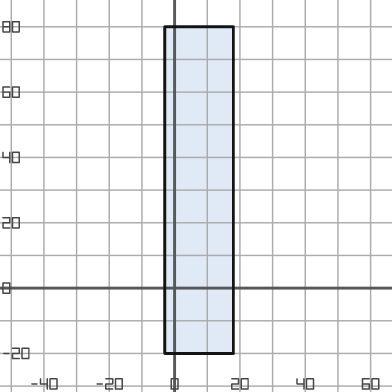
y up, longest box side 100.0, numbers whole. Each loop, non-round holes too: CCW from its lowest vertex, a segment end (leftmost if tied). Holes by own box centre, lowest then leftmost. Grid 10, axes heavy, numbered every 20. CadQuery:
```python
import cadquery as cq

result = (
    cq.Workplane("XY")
    .moveTo(-3.0, -20.0)
    .lineTo(18.0, -20.0)
    .lineTo(18.0, 80.0)
    .lineTo(-3.0, 80.0)
    .close()
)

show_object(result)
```